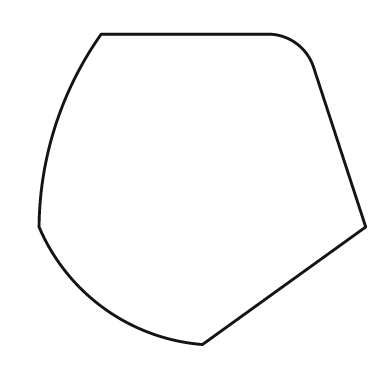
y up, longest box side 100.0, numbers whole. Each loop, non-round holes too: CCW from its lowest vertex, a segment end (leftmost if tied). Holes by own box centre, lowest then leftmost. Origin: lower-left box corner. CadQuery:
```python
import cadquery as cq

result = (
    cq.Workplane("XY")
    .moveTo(50.0, 0.0)
    .lineTo(100.0, 36.0)
    .lineTo(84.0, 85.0)
    .threePointArc((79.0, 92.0), (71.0, 95.0))
    .lineTo(19.0, 95.0)
    .threePointArc((5.0, 67.0), (0.0, 36.0))
    .threePointArc((20.0, 11.0), (50.0, 0.0))
    .close()
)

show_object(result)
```